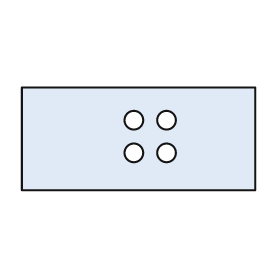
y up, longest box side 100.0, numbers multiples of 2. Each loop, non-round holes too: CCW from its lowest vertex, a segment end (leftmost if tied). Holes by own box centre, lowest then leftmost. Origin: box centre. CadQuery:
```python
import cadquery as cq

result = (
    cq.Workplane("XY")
    .moveTo(-50.0, -22.0)
    .lineTo(50.0, -22.0)
    .lineTo(50.0, 22.0)
    .lineTo(-50.0, 22.0)
    .close()
    .moveTo(-2.0, -6.0)
    .circle(4.0)
    .moveTo(12.0, -6.0)
    .circle(4.0)
    .moveTo(-2.0, 8.0)
    .circle(4.0)
    .moveTo(12.0, 8.0)
    .circle(4.0)
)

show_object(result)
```